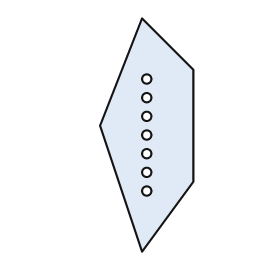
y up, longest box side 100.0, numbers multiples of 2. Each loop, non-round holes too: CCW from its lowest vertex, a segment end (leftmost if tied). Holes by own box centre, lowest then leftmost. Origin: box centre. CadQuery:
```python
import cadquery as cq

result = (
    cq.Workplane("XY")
    .moveTo(-2.0, -50.0)
    .lineTo(20.0, -20.0)
    .lineTo(20.0, 28.0)
    .lineTo(-2.0, 50.0)
    .lineTo(-20.0, 4.0)
    .close()
    .moveTo(0.0, -24.0)
    .circle(2.0)
    .moveTo(0.0, -16.0)
    .circle(2.0)
    .moveTo(0.0, -8.0)
    .circle(2.0)
    .moveTo(0.0, 0.0)
    .circle(2.0)
    .moveTo(0.0, 8.0)
    .circle(2.0)
    .moveTo(0.0, 16.0)
    .circle(2.0)
    .moveTo(0.0, 24.0)
    .circle(2.0)
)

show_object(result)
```